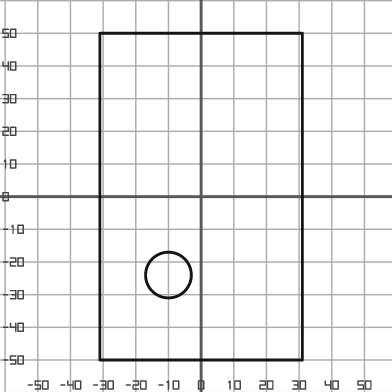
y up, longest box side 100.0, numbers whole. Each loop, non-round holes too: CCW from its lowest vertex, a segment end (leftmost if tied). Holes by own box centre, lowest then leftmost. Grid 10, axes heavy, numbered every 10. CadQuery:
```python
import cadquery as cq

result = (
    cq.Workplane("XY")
    .moveTo(-31.0, -50.0)
    .lineTo(31.0, -50.0)
    .lineTo(31.0, 50.0)
    .lineTo(-31.0, 50.0)
    .close()
    .moveTo(-10.0, -24.0)
    .circle(7.0)
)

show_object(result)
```